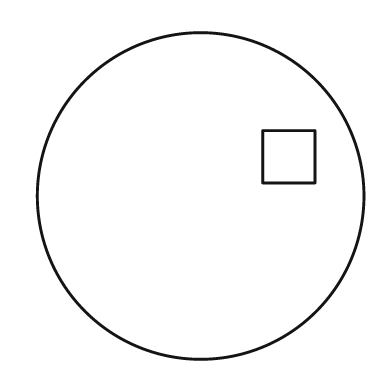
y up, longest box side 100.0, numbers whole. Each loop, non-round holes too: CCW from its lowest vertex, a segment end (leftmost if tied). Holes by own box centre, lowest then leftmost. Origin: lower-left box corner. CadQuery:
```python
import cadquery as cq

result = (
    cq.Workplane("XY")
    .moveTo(50.0, 50.0)
    .circle(50.0)
    .moveTo(69.0, 54.0)
    .lineTo(85.0, 54.0)
    .lineTo(85.0, 70.0)
    .lineTo(69.0, 70.0)
    .close()
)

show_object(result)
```